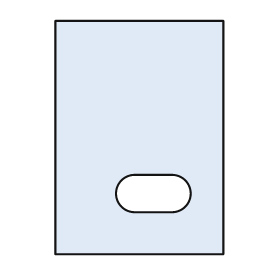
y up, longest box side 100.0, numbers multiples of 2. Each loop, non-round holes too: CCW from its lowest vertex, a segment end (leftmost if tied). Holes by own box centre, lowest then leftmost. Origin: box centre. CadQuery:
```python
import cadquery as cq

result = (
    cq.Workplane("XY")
    .moveTo(-36.0, -50.0)
    .lineTo(36.0, -50.0)
    .lineTo(36.0, 50.0)
    .lineTo(-36.0, 50.0)
    .close()
    .moveTo(-2.0, -32.0)
    .lineTo(14.0, -32.0)
    .threePointArc((22.0, -24.0), (14.0, -16.0))
    .lineTo(-2.0, -16.0)
    .threePointArc((-10.0, -24.0), (-2.0, -32.0))
    .close()
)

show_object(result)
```